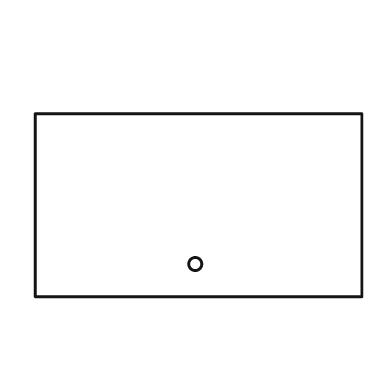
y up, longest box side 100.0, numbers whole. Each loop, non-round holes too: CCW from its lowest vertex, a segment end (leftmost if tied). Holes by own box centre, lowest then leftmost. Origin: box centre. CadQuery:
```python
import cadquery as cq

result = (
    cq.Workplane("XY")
    .moveTo(-50.0, -28.0)
    .lineTo(50.0, -28.0)
    .lineTo(50.0, 28.0)
    .lineTo(-50.0, 28.0)
    .close()
    .moveTo(-1.0, -18.0)
    .circle(2.0)
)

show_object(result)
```